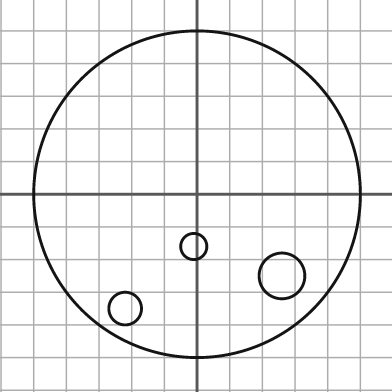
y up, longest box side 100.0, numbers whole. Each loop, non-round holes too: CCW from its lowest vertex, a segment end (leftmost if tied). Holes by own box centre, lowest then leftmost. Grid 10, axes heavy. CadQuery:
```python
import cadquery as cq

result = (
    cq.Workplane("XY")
    .moveTo(0.0, 0.0)
    .circle(50.0)
    .moveTo(-22.0, -35.0)
    .circle(5.0)
    .moveTo(26.0, -25.0)
    .circle(7.0)
    .moveTo(-1.0, -16.0)
    .circle(4.0)
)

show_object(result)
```